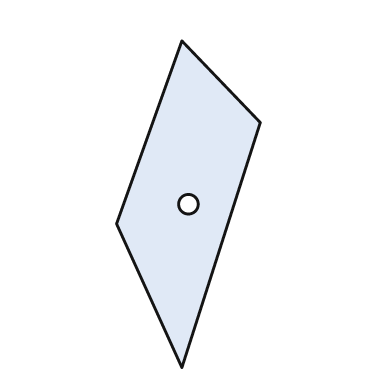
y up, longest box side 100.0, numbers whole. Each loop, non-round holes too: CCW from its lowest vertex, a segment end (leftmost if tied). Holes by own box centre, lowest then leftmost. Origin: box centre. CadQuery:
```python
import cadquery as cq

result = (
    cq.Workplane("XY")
    .moveTo(-2.0, -50.0)
    .lineTo(22.0, 25.0)
    .lineTo(-2.0, 50.0)
    .lineTo(-22.0, -6.0)
    .close()
    .moveTo(0.0, 0.0)
    .circle(3.0)
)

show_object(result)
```